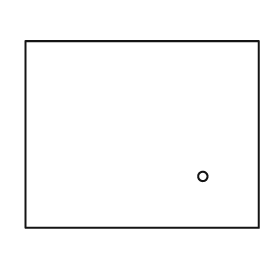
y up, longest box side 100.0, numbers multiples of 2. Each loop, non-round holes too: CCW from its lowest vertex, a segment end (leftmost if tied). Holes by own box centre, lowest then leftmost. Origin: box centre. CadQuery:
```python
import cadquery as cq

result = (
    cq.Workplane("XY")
    .moveTo(-50.0, -40.0)
    .lineTo(50.0, -40.0)
    .lineTo(50.0, 40.0)
    .lineTo(-50.0, 40.0)
    .close()
    .moveTo(26.0, -18.0)
    .circle(2.0)
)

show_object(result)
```